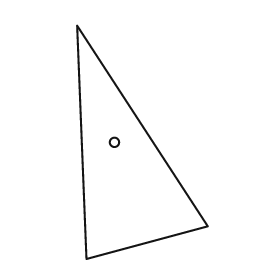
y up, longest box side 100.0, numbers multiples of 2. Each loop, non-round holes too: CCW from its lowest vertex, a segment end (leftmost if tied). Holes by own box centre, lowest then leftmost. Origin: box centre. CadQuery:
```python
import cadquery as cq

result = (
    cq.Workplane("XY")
    .moveTo(-24.0, -50.0)
    .lineTo(28.0, -36.0)
    .lineTo(-28.0, 50.0)
    .close()
    .moveTo(-12.0, 0.0)
    .circle(2.0)
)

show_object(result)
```